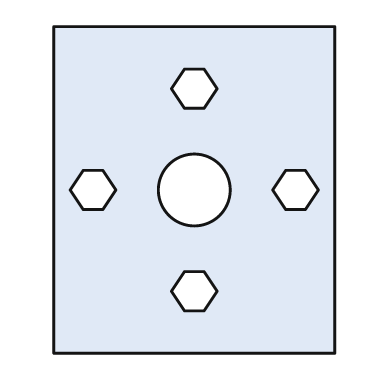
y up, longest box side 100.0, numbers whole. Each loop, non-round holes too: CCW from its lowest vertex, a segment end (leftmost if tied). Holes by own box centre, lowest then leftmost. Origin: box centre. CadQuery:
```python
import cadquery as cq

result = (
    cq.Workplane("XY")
    .moveTo(-43.0, -50.0)
    .lineTo(43.0, -50.0)
    .lineTo(43.0, 50.0)
    .lineTo(-43.0, 50.0)
    .close()
    .moveTo(-3.0, -37.0)
    .lineTo(3.0, -37.0)
    .lineTo(7.0, -31.0)
    .lineTo(3.0, -25.0)
    .lineTo(-3.0, -25.0)
    .lineTo(-7.0, -31.0)
    .close()
    .moveTo(-34.0, -6.0)
    .lineTo(-28.0, -6.0)
    .lineTo(-24.0, 0.0)
    .lineTo(-28.0, 6.0)
    .lineTo(-34.0, 6.0)
    .lineTo(-38.0, 0.0)
    .close()
    .moveTo(0.0, 0.0)
    .circle(11.0)
    .moveTo(28.0, -6.0)
    .lineTo(34.0, -6.0)
    .lineTo(38.0, 0.0)
    .lineTo(34.0, 6.0)
    .lineTo(28.0, 6.0)
    .lineTo(24.0, 0.0)
    .close()
    .moveTo(-3.0, 25.0)
    .lineTo(3.0, 25.0)
    .lineTo(7.0, 31.0)
    .lineTo(3.0, 37.0)
    .lineTo(-3.0, 37.0)
    .lineTo(-7.0, 31.0)
    .close()
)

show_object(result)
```